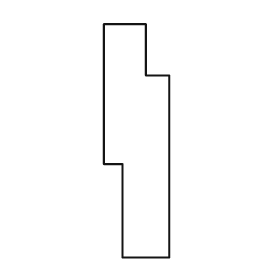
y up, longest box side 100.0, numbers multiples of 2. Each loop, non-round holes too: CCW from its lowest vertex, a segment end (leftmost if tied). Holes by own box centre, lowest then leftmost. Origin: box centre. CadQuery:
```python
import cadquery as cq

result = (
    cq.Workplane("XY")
    .moveTo(-6.0, -50.0)
    .lineTo(14.0, -50.0)
    .lineTo(14.0, 28.0)
    .lineTo(4.0, 28.0)
    .lineTo(4.0, 50.0)
    .lineTo(-14.0, 50.0)
    .lineTo(-14.0, -10.0)
    .lineTo(-6.0, -10.0)
    .close()
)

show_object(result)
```